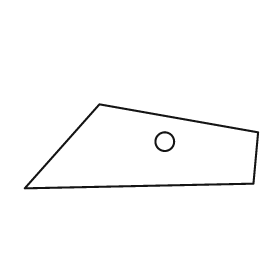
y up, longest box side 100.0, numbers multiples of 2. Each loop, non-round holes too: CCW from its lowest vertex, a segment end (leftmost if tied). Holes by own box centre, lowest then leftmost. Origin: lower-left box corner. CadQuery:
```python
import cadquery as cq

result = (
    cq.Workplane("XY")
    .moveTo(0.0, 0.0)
    .lineTo(98.0, 2.0)
    .lineTo(100.0, 24.0)
    .lineTo(32.0, 36.0)
    .close()
    .moveTo(60.0, 20.0)
    .circle(4.0)
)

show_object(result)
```